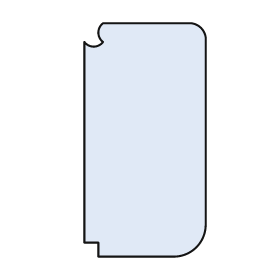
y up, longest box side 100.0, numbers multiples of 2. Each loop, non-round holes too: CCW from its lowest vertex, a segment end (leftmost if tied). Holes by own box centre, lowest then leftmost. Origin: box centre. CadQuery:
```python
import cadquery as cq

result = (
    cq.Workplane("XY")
    .moveTo(-20.0, -50.0)
    .lineTo(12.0, -50.0)
    .threePointArc((22.0, -46.0), (26.0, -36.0))
    .lineTo(26.0, 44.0)
    .threePointArc((24.0, 48.0), (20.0, 50.0))
    .lineTo(-18.0, 50.0)
    .threePointArc((-20.0, 46.0), (-18.0, 42.0))
    .threePointArc((-22.0, 40.0), (-26.0, 42.0))
    .lineTo(-26.0, -44.0)
    .lineTo(-20.0, -44.0)
    .close()
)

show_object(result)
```